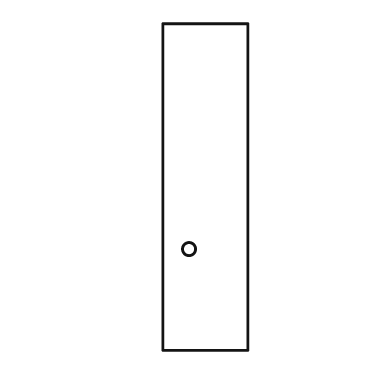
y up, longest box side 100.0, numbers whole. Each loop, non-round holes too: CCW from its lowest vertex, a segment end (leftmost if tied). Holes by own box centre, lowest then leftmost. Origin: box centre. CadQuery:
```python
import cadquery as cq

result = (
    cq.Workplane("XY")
    .moveTo(-13.0, -50.0)
    .lineTo(13.0, -50.0)
    .lineTo(13.0, 50.0)
    .lineTo(-13.0, 50.0)
    .close()
    .moveTo(-5.0, -19.0)
    .circle(2.0)
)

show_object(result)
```